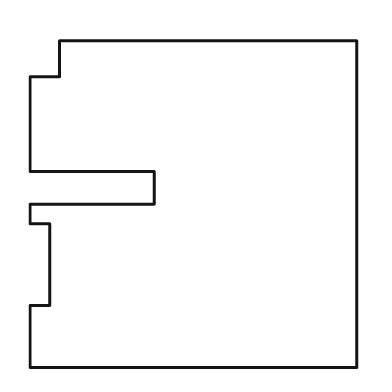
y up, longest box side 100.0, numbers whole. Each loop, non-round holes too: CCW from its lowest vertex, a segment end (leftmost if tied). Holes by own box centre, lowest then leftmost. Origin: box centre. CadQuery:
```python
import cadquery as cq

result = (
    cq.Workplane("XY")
    .moveTo(-50.0, -50.0)
    .lineTo(50.0, -50.0)
    .lineTo(50.0, 50.0)
    .lineTo(-41.0, 50.0)
    .lineTo(-41.0, 39.0)
    .lineTo(-50.0, 39.0)
    .lineTo(-50.0, 10.0)
    .lineTo(-12.0, 10.0)
    .lineTo(-12.0, 0.0)
    .lineTo(-50.0, 0.0)
    .lineTo(-50.0, -6.0)
    .lineTo(-44.0, -6.0)
    .lineTo(-44.0, -31.0)
    .lineTo(-50.0, -31.0)
    .close()
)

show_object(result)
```